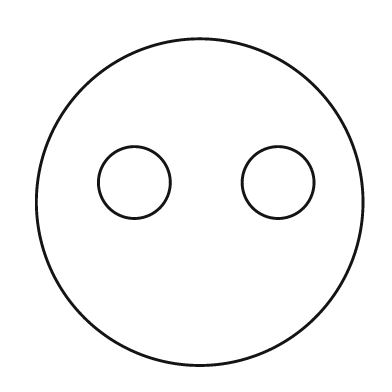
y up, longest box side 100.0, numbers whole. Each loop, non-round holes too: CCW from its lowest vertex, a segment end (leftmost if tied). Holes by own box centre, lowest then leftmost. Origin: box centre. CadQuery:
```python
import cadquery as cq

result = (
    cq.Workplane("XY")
    .moveTo(0.0, 0.0)
    .circle(50.0)
    .moveTo(-20.0, 6.0)
    .circle(11.0)
    .moveTo(24.0, 6.0)
    .circle(11.0)
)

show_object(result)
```